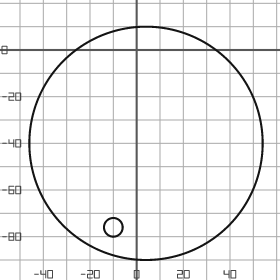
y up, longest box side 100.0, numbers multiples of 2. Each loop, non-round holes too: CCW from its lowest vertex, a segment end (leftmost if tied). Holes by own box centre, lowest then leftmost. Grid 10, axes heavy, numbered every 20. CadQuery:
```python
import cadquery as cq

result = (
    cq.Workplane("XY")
    .moveTo(4.0, -40.0)
    .circle(50.0)
    .moveTo(-10.0, -76.0)
    .circle(4.0)
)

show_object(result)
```